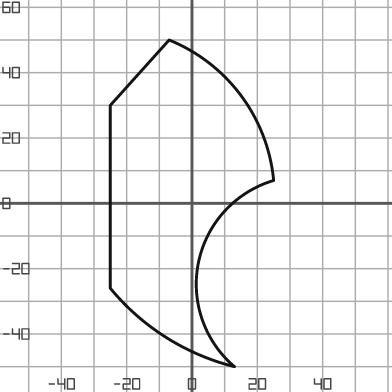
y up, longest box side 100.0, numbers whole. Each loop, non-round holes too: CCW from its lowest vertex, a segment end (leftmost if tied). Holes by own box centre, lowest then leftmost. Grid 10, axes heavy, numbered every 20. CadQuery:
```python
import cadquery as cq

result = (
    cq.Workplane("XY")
    .moveTo(13.0, -50.0)
    .threePointArc((2.0, -18.0), (25.0, 7.0))
    .threePointArc((15.0, 33.0), (-7.0, 50.0))
    .lineTo(-25.0, 30.0)
    .lineTo(-25.0, -26.0)
    .threePointArc((-8.0, -41.0), (13.0, -50.0))
    .close()
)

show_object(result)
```